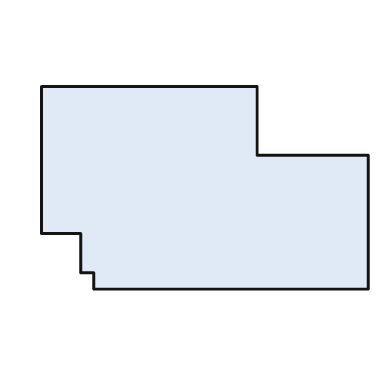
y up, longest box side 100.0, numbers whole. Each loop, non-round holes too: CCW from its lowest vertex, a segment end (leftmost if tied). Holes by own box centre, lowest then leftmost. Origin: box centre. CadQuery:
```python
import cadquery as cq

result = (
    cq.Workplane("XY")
    .moveTo(-34.0, -31.0)
    .lineTo(50.0, -31.0)
    .lineTo(50.0, 10.0)
    .lineTo(16.0, 10.0)
    .lineTo(16.0, 31.0)
    .lineTo(-50.0, 31.0)
    .lineTo(-50.0, -14.0)
    .lineTo(-38.0, -14.0)
    .lineTo(-38.0, -26.0)
    .lineTo(-34.0, -26.0)
    .close()
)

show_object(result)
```